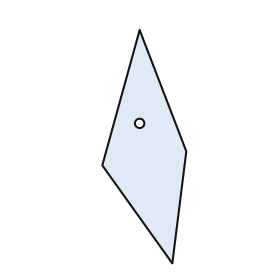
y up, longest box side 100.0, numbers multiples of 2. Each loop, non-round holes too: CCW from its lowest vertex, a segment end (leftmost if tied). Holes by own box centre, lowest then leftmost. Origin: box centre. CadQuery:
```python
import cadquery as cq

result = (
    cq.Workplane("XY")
    .moveTo(12.0, -50.0)
    .lineTo(18.0, -2.0)
    .lineTo(-2.0, 50.0)
    .lineTo(-18.0, -8.0)
    .close()
    .moveTo(-2.0, 10.0)
    .circle(2.0)
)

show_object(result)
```